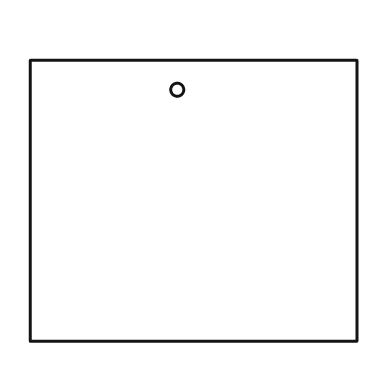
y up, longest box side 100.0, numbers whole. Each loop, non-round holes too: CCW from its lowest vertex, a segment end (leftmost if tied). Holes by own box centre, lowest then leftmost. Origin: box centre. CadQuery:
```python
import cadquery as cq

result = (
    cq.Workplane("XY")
    .moveTo(-50.0, -43.0)
    .lineTo(50.0, -43.0)
    .lineTo(50.0, 43.0)
    .lineTo(-50.0, 43.0)
    .close()
    .moveTo(-5.0, 34.0)
    .circle(2.0)
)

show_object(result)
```